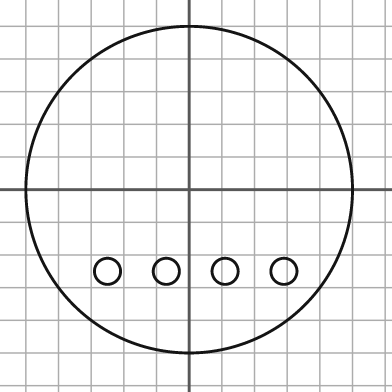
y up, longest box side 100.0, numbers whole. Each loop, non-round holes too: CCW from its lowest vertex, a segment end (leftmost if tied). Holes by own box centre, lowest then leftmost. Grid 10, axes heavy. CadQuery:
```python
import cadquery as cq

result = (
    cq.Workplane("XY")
    .moveTo(0.0, 0.0)
    .circle(50.0)
    .moveTo(-25.0, -25.0)
    .circle(4.0)
    .moveTo(-7.0, -25.0)
    .circle(4.0)
    .moveTo(11.0, -25.0)
    .circle(4.0)
    .moveTo(29.0, -25.0)
    .circle(4.0)
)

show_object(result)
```